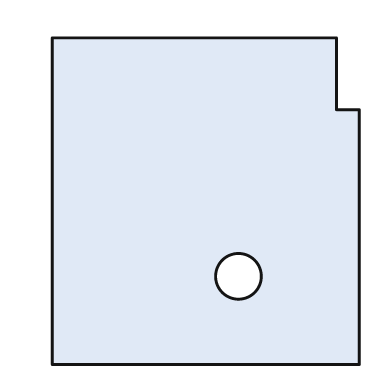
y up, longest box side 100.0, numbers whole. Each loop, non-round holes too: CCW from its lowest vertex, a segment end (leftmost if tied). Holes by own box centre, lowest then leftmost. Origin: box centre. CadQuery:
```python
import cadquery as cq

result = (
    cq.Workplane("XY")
    .moveTo(-47.0, -50.0)
    .lineTo(47.0, -50.0)
    .lineTo(47.0, 28.0)
    .lineTo(40.0, 28.0)
    .lineTo(40.0, 50.0)
    .lineTo(-47.0, 50.0)
    .close()
    .moveTo(10.0, -23.0)
    .circle(7.0)
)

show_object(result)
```